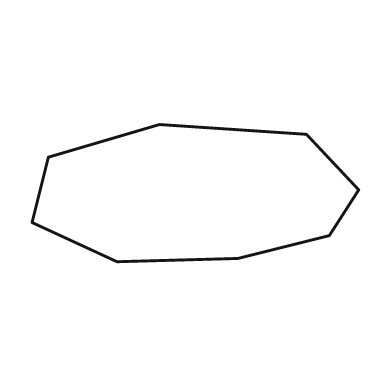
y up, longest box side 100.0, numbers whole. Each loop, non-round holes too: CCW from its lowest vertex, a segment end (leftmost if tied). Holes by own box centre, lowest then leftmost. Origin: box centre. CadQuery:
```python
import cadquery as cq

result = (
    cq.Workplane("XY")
    .moveTo(-24.0, -21.0)
    .lineTo(13.0, -20.0)
    .lineTo(41.0, -13.0)
    .lineTo(50.0, 1.0)
    .lineTo(34.0, 18.0)
    .lineTo(-11.0, 21.0)
    .lineTo(-45.0, 11.0)
    .lineTo(-50.0, -9.0)
    .close()
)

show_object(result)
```